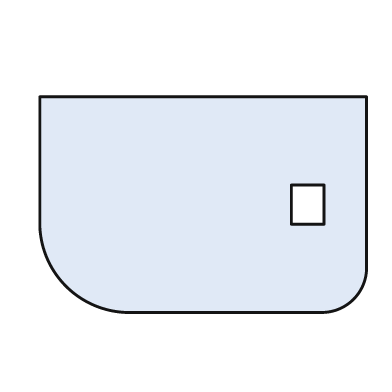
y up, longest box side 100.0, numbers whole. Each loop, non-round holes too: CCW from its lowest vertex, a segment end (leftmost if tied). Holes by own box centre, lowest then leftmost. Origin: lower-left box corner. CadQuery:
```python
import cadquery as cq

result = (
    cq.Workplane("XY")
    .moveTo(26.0, 0.0)
    .lineTo(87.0, 0.0)
    .threePointArc((96.0, 4.0), (100.0, 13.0))
    .lineTo(100.0, 66.0)
    .lineTo(0.0, 66.0)
    .lineTo(0.0, 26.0)
    .threePointArc((8.0, 8.0), (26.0, 0.0))
    .close()
    .moveTo(77.0, 27.0)
    .lineTo(87.0, 27.0)
    .lineTo(87.0, 39.0)
    .lineTo(77.0, 39.0)
    .close()
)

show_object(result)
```